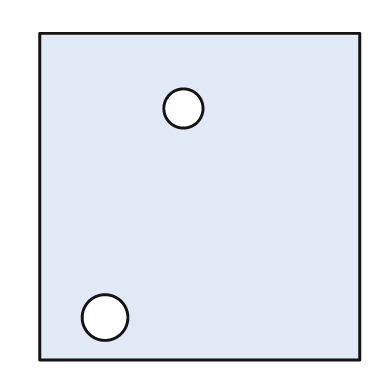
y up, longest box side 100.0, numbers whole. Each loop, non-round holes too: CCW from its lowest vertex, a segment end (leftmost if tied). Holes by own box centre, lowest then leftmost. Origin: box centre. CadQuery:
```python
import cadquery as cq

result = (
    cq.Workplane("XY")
    .moveTo(-49.0, -50.0)
    .lineTo(49.0, -50.0)
    .lineTo(49.0, 50.0)
    .lineTo(-49.0, 50.0)
    .close()
    .moveTo(-29.0, -37.0)
    .circle(7.0)
    .moveTo(-5.0, 27.0)
    .circle(6.0)
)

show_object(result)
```